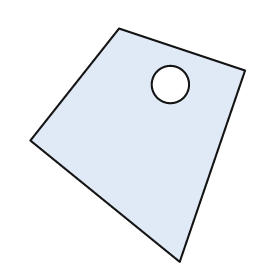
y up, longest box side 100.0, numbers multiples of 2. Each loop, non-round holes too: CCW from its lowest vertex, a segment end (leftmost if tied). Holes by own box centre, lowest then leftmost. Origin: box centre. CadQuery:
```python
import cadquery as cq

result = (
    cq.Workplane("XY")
    .moveTo(18.0, -50.0)
    .lineTo(46.0, 32.0)
    .lineTo(-8.0, 50.0)
    .lineTo(-46.0, 2.0)
    .close()
    .moveTo(14.0, 26.0)
    .circle(8.0)
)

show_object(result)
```